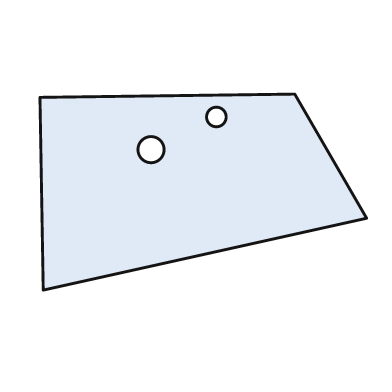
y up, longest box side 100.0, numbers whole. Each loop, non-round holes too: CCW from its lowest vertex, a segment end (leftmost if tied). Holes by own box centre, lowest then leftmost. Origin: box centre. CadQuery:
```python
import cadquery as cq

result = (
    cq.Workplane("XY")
    .moveTo(-49.0, -30.0)
    .lineTo(50.0, -8.0)
    .lineTo(28.0, 30.0)
    .lineTo(-50.0, 29.0)
    .close()
    .moveTo(-16.0, 13.0)
    .circle(4.0)
    .moveTo(4.0, 23.0)
    .circle(3.0)
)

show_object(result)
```